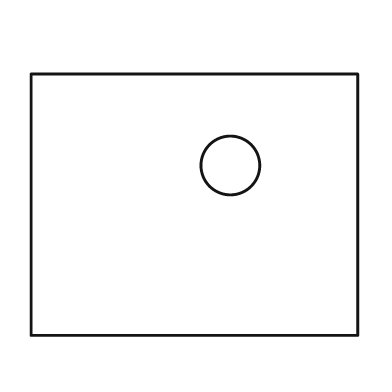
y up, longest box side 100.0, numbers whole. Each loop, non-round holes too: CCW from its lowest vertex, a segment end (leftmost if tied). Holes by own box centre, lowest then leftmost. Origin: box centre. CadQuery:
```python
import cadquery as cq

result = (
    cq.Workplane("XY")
    .moveTo(-50.0, -40.0)
    .lineTo(50.0, -40.0)
    .lineTo(50.0, 40.0)
    .lineTo(-50.0, 40.0)
    .close()
    .moveTo(11.0, 12.0)
    .circle(9.0)
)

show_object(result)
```